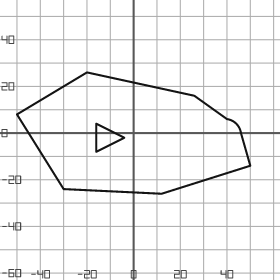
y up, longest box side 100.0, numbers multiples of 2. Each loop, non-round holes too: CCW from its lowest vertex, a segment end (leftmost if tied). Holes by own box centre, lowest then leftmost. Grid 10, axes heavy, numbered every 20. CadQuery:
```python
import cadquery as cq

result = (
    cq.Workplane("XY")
    .moveTo(12.0, -26.0)
    .lineTo(50.0, -14.0)
    .lineTo(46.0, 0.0)
    .threePointArc((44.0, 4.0), (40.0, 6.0))
    .lineTo(26.0, 16.0)
    .lineTo(-20.0, 26.0)
    .lineTo(-50.0, 8.0)
    .lineTo(-30.0, -24.0)
    .close()
    .moveTo(-16.0, -8.0)
    .lineTo(-4.0, -2.0)
    .lineTo(-16.0, 4.0)
    .close()
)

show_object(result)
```